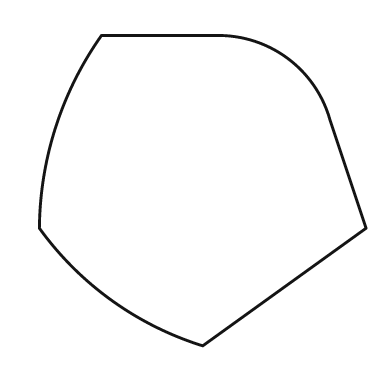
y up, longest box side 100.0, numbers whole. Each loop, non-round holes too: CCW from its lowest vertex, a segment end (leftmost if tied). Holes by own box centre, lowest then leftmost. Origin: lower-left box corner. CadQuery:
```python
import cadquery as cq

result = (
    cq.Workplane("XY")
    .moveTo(50.0, 0.0)
    .lineTo(100.0, 36.0)
    .lineTo(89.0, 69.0)
    .threePointArc((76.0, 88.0), (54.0, 95.0))
    .lineTo(19.0, 95.0)
    .threePointArc((5.0, 67.0), (0.0, 36.0))
    .threePointArc((22.0, 14.0), (50.0, 0.0))
    .close()
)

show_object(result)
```